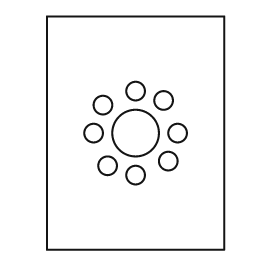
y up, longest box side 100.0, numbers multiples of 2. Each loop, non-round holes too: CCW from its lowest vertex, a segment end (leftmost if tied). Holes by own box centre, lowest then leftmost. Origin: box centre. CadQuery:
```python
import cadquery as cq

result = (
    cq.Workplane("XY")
    .moveTo(-38.0, -50.0)
    .lineTo(38.0, -50.0)
    .lineTo(38.0, 50.0)
    .lineTo(-38.0, 50.0)
    .close()
    .moveTo(0.0, -18.0)
    .circle(4.0)
    .moveTo(-12.0, -14.0)
    .circle(4.0)
    .moveTo(14.0, -12.0)
    .circle(4.0)
    .moveTo(-18.0, 0.0)
    .circle(4.0)
    .moveTo(0.0, 0.0)
    .circle(10.0)
    .moveTo(18.0, 0.0)
    .circle(4.0)
    .moveTo(-14.0, 12.0)
    .circle(4.0)
    .moveTo(12.0, 14.0)
    .circle(4.0)
    .moveTo(0.0, 18.0)
    .circle(4.0)
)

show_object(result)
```